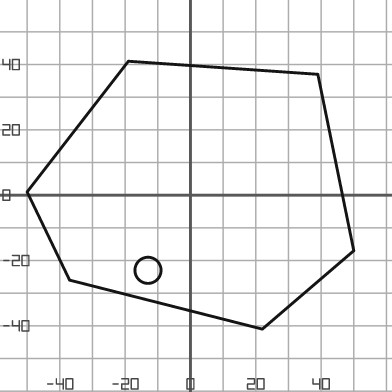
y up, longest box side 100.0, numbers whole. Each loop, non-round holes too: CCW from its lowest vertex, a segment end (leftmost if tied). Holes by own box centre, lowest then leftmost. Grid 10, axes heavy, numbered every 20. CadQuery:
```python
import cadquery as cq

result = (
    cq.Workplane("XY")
    .moveTo(22.0, -41.0)
    .lineTo(50.0, -17.0)
    .lineTo(39.0, 37.0)
    .lineTo(-19.0, 41.0)
    .lineTo(-50.0, 1.0)
    .lineTo(-37.0, -26.0)
    .close()
    .moveTo(-13.0, -23.0)
    .circle(4.0)
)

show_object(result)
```